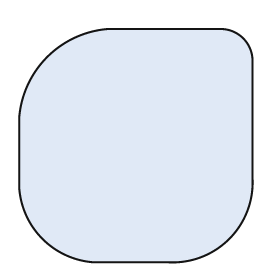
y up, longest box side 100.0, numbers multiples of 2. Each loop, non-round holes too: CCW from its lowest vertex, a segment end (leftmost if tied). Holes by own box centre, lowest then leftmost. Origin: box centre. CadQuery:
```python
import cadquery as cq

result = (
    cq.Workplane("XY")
    .moveTo(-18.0, -50.0)
    .lineTo(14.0, -50.0)
    .threePointArc((40.0, -40.0), (50.0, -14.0))
    .lineTo(50.0, 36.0)
    .threePointArc((46.0, 46.0), (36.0, 50.0))
    .lineTo(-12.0, 50.0)
    .threePointArc((-38.0, 38.0), (-50.0, 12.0))
    .lineTo(-50.0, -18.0)
    .threePointArc((-40.0, -40.0), (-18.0, -50.0))
    .close()
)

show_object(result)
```